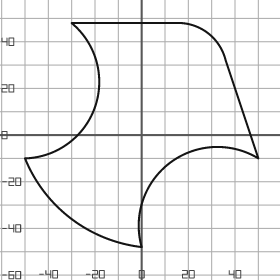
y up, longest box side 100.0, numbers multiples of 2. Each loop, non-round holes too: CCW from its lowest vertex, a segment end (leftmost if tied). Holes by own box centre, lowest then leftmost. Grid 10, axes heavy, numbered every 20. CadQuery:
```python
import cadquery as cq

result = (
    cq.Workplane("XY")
    .moveTo(0.0, -48.0)
    .threePointArc((12.0, -12.0), (50.0, -10.0))
    .lineTo(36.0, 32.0)
    .threePointArc((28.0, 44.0), (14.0, 48.0))
    .lineTo(-30.0, 48.0)
    .threePointArc((-20.0, 12.0), (-50.0, -10.0))
    .threePointArc((-30.0, -36.0), (0.0, -48.0))
    .close()
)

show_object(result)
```